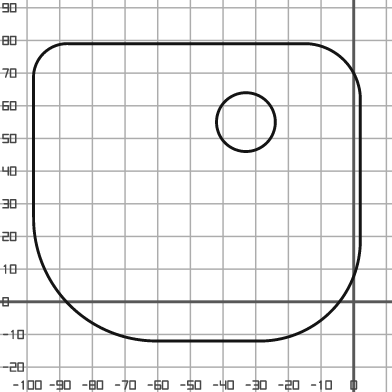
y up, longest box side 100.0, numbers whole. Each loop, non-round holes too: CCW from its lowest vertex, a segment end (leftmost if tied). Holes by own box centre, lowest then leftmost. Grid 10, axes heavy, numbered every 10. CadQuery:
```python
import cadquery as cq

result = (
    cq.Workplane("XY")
    .moveTo(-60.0, -12.0)
    .lineTo(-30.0, -12.0)
    .threePointArc((-7.0, -3.0), (2.0, 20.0))
    .lineTo(2.0, 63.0)
    .threePointArc((-3.0, 74.0), (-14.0, 79.0))
    .lineTo(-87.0, 79.0)
    .threePointArc((-95.0, 76.0), (-98.0, 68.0))
    .lineTo(-98.0, 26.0)
    .threePointArc((-87.0, -1.0), (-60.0, -12.0))
    .close()
    .moveTo(-33.0, 55.0)
    .circle(9.0)
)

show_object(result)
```